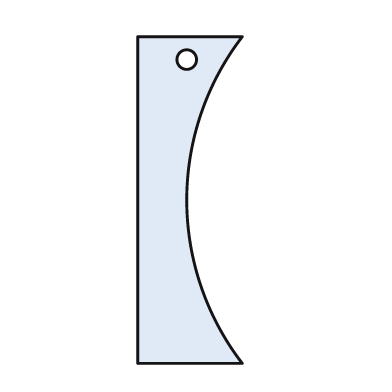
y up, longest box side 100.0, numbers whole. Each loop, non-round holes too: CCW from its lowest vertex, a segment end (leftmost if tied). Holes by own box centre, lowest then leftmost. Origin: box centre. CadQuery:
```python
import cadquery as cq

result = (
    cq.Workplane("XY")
    .moveTo(-16.0, -50.0)
    .lineTo(16.0, -50.0)
    .threePointArc((-1.0, 0.0), (16.0, 50.0))
    .lineTo(-16.0, 50.0)
    .close()
    .moveTo(-1.0, 43.0)
    .circle(3.0)
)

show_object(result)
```